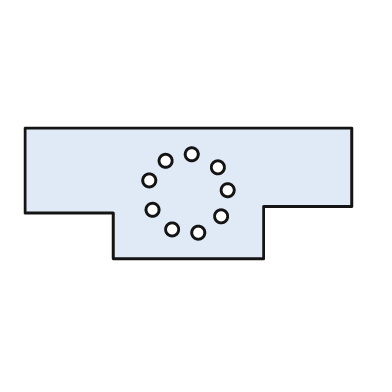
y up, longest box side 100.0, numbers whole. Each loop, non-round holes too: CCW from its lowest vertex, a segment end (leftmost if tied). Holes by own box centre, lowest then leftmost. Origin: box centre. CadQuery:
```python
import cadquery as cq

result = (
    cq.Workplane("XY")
    .moveTo(-23.0, -20.0)
    .lineTo(23.0, -20.0)
    .lineTo(23.0, -4.0)
    .lineTo(50.0, -4.0)
    .lineTo(50.0, 20.0)
    .lineTo(-50.0, 20.0)
    .lineTo(-50.0, -6.0)
    .lineTo(-23.0, -6.0)
    .close()
    .moveTo(3.0, -12.0)
    .circle(2.0)
    .moveTo(-5.0, -11.0)
    .circle(2.0)
    .moveTo(10.0, -7.0)
    .circle(2.0)
    .moveTo(-11.0, -5.0)
    .circle(2.0)
    .moveTo(12.0, 1.0)
    .circle(2.0)
    .moveTo(-12.0, 4.0)
    .circle(2.0)
    .moveTo(9.0, 8.0)
    .circle(2.0)
    .moveTo(-7.0, 10.0)
    .circle(2.0)
    .moveTo(1.0, 12.0)
    .circle(2.0)
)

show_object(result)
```